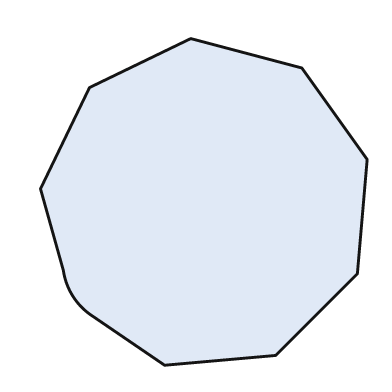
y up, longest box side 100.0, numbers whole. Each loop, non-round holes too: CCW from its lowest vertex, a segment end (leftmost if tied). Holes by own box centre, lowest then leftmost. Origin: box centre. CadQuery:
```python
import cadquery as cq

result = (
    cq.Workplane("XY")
    .moveTo(-12.0, -50.0)
    .lineTo(22.0, -47.0)
    .lineTo(47.0, -22.0)
    .lineTo(50.0, 13.0)
    .lineTo(30.0, 41.0)
    .lineTo(-4.0, 50.0)
    .lineTo(-35.0, 35.0)
    .lineTo(-50.0, 4.0)
    .lineTo(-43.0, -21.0)
    .threePointArc((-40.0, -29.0), (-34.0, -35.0))
    .close()
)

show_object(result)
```